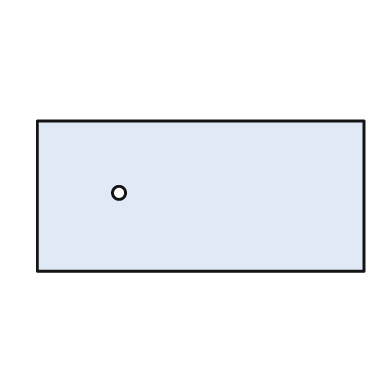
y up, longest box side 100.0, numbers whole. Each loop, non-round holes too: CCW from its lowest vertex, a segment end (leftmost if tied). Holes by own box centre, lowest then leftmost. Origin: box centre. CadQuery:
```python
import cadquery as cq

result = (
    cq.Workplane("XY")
    .moveTo(-50.0, -23.0)
    .lineTo(50.0, -23.0)
    .lineTo(50.0, 23.0)
    .lineTo(-50.0, 23.0)
    .close()
    .moveTo(-25.0, 1.0)
    .circle(2.0)
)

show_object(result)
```